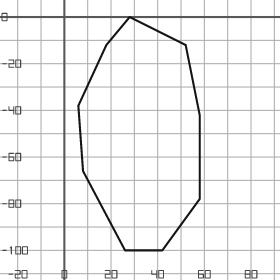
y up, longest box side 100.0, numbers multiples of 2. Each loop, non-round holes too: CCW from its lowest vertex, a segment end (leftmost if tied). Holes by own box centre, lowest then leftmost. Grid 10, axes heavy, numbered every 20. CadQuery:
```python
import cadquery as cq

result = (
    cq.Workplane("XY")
    .moveTo(26.0, -100.0)
    .lineTo(42.0, -100.0)
    .lineTo(58.0, -78.0)
    .lineTo(58.0, -42.0)
    .lineTo(52.0, -12.0)
    .lineTo(28.0, 0.0)
    .lineTo(18.0, -12.0)
    .lineTo(6.0, -38.0)
    .lineTo(8.0, -66.0)
    .close()
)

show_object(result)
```